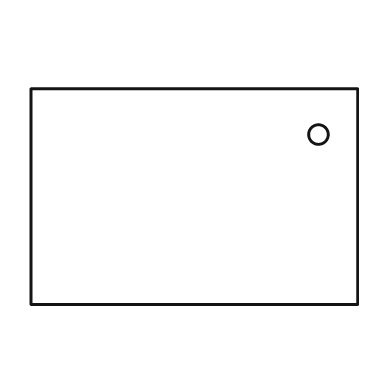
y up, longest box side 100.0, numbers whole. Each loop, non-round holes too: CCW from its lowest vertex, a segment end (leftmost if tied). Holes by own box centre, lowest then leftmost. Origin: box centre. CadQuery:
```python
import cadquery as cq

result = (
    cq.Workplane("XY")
    .moveTo(-50.0, -33.0)
    .lineTo(50.0, -33.0)
    .lineTo(50.0, 33.0)
    .lineTo(-50.0, 33.0)
    .close()
    .moveTo(38.0, 19.0)
    .circle(3.0)
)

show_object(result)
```